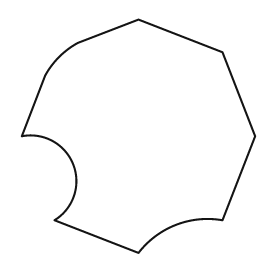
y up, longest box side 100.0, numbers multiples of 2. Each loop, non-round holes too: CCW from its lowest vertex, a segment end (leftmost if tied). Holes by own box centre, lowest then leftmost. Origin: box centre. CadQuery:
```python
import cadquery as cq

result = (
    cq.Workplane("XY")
    .moveTo(0.0, -50.0)
    .threePointArc((16.0, -38.0), (36.0, -36.0))
    .lineTo(50.0, 0.0)
    .lineTo(36.0, 36.0)
    .lineTo(0.0, 50.0)
    .lineTo(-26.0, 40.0)
    .threePointArc((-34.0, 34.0), (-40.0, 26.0))
    .lineTo(-50.0, 0.0)
    .threePointArc((-28.0, -12.0), (-36.0, -36.0))
    .close()
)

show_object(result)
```